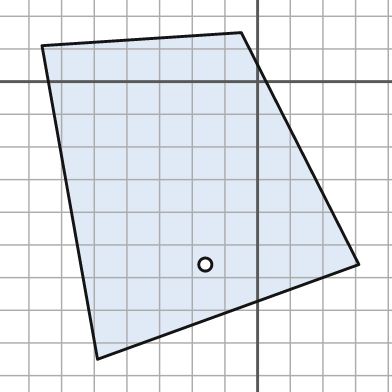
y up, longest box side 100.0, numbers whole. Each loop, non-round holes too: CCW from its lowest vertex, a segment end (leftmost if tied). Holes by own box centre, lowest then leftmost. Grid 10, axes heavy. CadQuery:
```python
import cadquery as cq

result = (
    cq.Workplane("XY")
    .moveTo(-49.0, -85.0)
    .lineTo(31.0, -56.0)
    .lineTo(-5.0, 15.0)
    .lineTo(-66.0, 11.0)
    .close()
    .moveTo(-16.0, -56.0)
    .circle(2.0)
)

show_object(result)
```